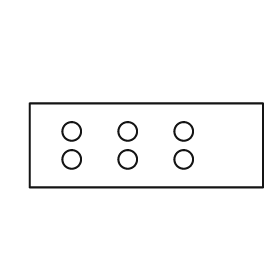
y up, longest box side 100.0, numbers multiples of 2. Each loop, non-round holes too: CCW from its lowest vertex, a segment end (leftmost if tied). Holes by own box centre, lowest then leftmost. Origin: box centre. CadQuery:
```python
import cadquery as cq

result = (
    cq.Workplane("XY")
    .moveTo(-50.0, -18.0)
    .lineTo(50.0, -18.0)
    .lineTo(50.0, 18.0)
    .lineTo(-50.0, 18.0)
    .close()
    .moveTo(-32.0, -6.0)
    .circle(4.0)
    .moveTo(-8.0, -6.0)
    .circle(4.0)
    .moveTo(16.0, -6.0)
    .circle(4.0)
    .moveTo(-32.0, 6.0)
    .circle(4.0)
    .moveTo(-8.0, 6.0)
    .circle(4.0)
    .moveTo(16.0, 6.0)
    .circle(4.0)
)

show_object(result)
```